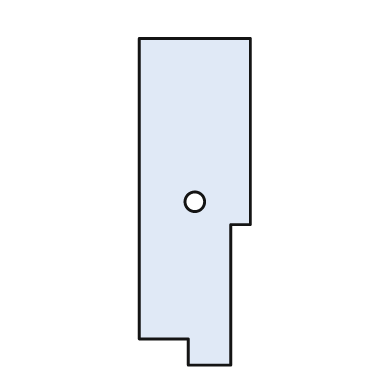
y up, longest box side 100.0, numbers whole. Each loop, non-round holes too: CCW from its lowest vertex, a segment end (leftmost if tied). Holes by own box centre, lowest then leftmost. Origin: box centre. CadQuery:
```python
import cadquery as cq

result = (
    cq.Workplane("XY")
    .moveTo(-2.0, -50.0)
    .lineTo(11.0, -50.0)
    .lineTo(11.0, -7.0)
    .lineTo(17.0, -7.0)
    .lineTo(17.0, 50.0)
    .lineTo(-17.0, 50.0)
    .lineTo(-17.0, -42.0)
    .lineTo(-2.0, -42.0)
    .close()
    .moveTo(0.0, 0.0)
    .circle(3.0)
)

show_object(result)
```